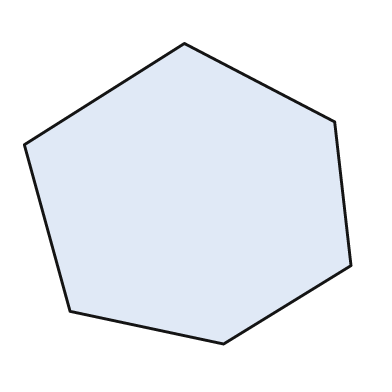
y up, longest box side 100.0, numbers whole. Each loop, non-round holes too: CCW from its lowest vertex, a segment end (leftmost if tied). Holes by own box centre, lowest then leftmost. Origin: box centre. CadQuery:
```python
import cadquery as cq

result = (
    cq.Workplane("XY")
    .moveTo(11.0, -46.0)
    .lineTo(50.0, -22.0)
    .lineTo(45.0, 22.0)
    .lineTo(-1.0, 46.0)
    .lineTo(-50.0, 15.0)
    .lineTo(-36.0, -36.0)
    .close()
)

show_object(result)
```